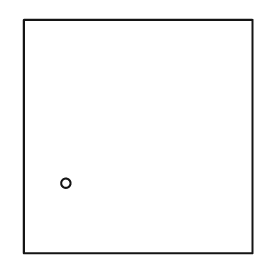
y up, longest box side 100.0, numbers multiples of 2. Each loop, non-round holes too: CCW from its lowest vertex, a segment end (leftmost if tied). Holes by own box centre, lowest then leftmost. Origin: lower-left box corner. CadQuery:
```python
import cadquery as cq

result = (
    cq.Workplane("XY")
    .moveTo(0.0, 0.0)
    .lineTo(98.0, 0.0)
    .lineTo(98.0, 100.0)
    .lineTo(0.0, 100.0)
    .close()
    .moveTo(18.0, 30.0)
    .circle(2.0)
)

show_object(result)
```